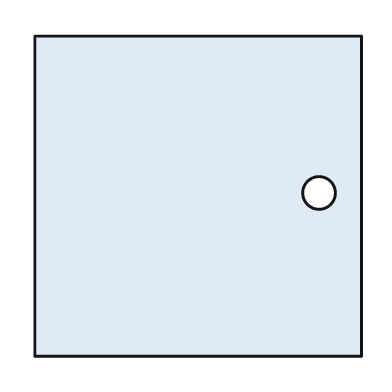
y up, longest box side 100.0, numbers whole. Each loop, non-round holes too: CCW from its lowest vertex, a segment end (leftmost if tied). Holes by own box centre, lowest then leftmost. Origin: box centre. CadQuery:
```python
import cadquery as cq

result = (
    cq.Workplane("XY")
    .moveTo(-50.0, -49.0)
    .lineTo(50.0, -49.0)
    .lineTo(50.0, 49.0)
    .lineTo(-50.0, 49.0)
    .close()
    .moveTo(37.0, 1.0)
    .circle(5.0)
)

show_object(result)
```